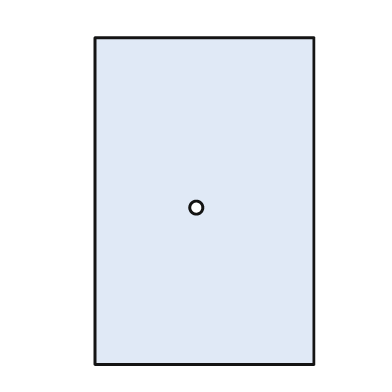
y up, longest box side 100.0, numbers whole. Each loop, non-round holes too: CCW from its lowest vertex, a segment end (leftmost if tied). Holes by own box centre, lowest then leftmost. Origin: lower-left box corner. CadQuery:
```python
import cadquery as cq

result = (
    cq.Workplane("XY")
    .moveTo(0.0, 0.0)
    .lineTo(67.0, 0.0)
    .lineTo(67.0, 100.0)
    .lineTo(0.0, 100.0)
    .close()
    .moveTo(31.0, 48.0)
    .circle(2.0)
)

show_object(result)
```